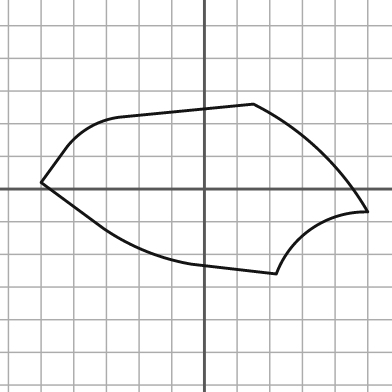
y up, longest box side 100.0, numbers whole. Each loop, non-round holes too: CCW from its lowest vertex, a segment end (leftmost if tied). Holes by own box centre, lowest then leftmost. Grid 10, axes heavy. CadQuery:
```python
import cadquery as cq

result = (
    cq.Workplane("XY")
    .moveTo(22.0, -26.0)
    .threePointArc((33.0, -12.0), (50.0, -7.0))
    .threePointArc((35.0, 12.0), (15.0, 26.0))
    .lineTo(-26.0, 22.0)
    .threePointArc((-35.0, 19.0), (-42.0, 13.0))
    .lineTo(-50.0, 2.0)
    .lineTo(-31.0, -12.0)
    .threePointArc((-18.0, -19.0), (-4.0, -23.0))
    .close()
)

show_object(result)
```